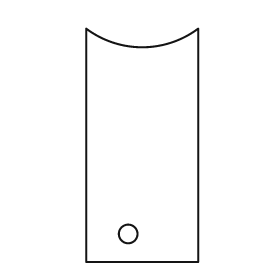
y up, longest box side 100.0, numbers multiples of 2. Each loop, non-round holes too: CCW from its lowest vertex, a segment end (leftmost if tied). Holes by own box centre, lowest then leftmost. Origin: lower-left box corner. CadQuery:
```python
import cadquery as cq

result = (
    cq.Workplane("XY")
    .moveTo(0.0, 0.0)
    .lineTo(48.0, 0.0)
    .lineTo(48.0, 100.0)
    .threePointArc((24.0, 92.0), (0.0, 100.0))
    .close()
    .moveTo(18.0, 12.0)
    .circle(4.0)
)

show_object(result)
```